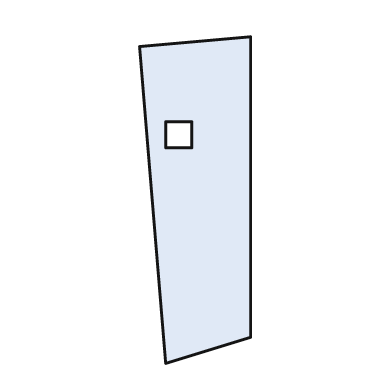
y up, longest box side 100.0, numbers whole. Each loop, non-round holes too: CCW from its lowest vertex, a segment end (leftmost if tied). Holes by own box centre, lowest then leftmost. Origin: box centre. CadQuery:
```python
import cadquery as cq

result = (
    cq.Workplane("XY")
    .moveTo(-9.0, -50.0)
    .lineTo(17.0, -42.0)
    .lineTo(17.0, 50.0)
    .lineTo(-17.0, 47.0)
    .close()
    .moveTo(-9.0, 16.0)
    .lineTo(-1.0, 16.0)
    .lineTo(-1.0, 24.0)
    .lineTo(-9.0, 24.0)
    .close()
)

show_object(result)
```